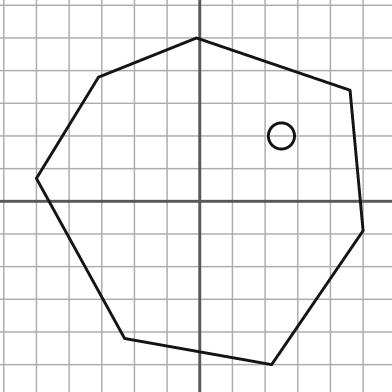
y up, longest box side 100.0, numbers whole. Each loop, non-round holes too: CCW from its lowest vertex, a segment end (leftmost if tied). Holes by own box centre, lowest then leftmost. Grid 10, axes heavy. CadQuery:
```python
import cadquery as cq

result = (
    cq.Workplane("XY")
    .moveTo(22.0, -50.0)
    .lineTo(50.0, -9.0)
    .lineTo(46.0, 34.0)
    .lineTo(-1.0, 50.0)
    .lineTo(-31.0, 38.0)
    .lineTo(-50.0, 7.0)
    .lineTo(-23.0, -42.0)
    .close()
    .moveTo(25.0, 20.0)
    .circle(4.0)
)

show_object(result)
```